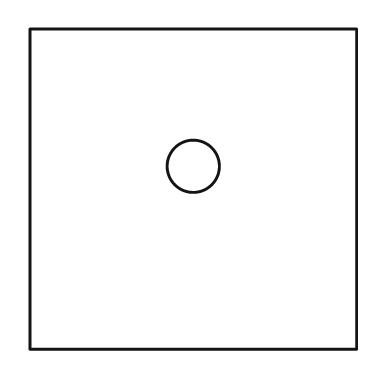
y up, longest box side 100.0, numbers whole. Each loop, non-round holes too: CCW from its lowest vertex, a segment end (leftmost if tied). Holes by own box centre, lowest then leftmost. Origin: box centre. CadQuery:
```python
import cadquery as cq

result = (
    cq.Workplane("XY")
    .moveTo(-50.0, -49.0)
    .lineTo(50.0, -49.0)
    .lineTo(50.0, 49.0)
    .lineTo(-50.0, 49.0)
    .close()
    .moveTo(0.0, 7.0)
    .circle(8.0)
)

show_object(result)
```